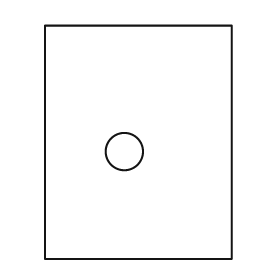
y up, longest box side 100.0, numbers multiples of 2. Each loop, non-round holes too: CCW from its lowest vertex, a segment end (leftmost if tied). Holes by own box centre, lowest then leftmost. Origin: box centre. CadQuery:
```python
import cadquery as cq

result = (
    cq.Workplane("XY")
    .moveTo(-40.0, -50.0)
    .lineTo(40.0, -50.0)
    .lineTo(40.0, 50.0)
    .lineTo(-40.0, 50.0)
    .close()
    .moveTo(-6.0, -4.0)
    .circle(8.0)
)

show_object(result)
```